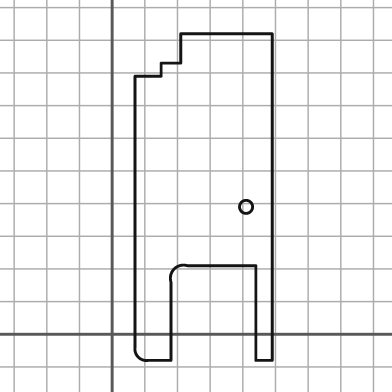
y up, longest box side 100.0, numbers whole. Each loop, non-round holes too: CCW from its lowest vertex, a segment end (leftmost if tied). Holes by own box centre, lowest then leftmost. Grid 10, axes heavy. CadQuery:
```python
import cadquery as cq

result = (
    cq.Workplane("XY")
    .moveTo(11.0, -8.0)
    .lineTo(18.0, -8.0)
    .lineTo(18.0, 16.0)
    .threePointArc((19.0, 20.0), (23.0, 21.0))
    .lineTo(44.0, 21.0)
    .lineTo(44.0, -8.0)
    .lineTo(49.0, -8.0)
    .lineTo(49.0, 92.0)
    .lineTo(21.0, 92.0)
    .lineTo(21.0, 83.0)
    .lineTo(15.0, 83.0)
    .lineTo(15.0, 79.0)
    .lineTo(7.0, 79.0)
    .lineTo(7.0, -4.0)
    .threePointArc((8.0, -7.0), (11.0, -8.0))
    .close()
    .moveTo(41.0, 39.0)
    .circle(2.0)
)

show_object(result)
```